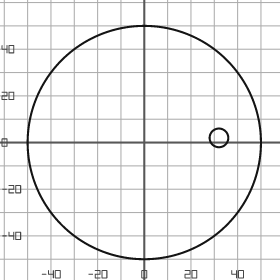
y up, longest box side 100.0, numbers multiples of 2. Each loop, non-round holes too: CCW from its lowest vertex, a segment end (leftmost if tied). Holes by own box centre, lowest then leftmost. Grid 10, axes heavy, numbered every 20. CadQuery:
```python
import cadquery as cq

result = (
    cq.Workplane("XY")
    .moveTo(0.0, 0.0)
    .circle(50.0)
    .moveTo(32.0, 2.0)
    .circle(4.0)
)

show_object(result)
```